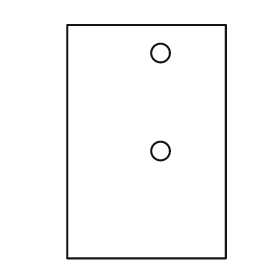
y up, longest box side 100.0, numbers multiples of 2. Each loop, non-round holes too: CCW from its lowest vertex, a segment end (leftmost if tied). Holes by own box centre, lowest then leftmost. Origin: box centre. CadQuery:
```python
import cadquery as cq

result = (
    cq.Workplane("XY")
    .moveTo(-34.0, -50.0)
    .lineTo(34.0, -50.0)
    .lineTo(34.0, 50.0)
    .lineTo(-34.0, 50.0)
    .close()
    .moveTo(6.0, -4.0)
    .circle(4.0)
    .moveTo(6.0, 38.0)
    .circle(4.0)
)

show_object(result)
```